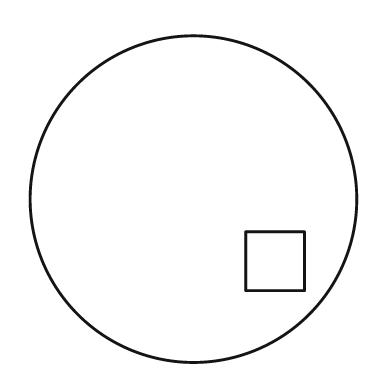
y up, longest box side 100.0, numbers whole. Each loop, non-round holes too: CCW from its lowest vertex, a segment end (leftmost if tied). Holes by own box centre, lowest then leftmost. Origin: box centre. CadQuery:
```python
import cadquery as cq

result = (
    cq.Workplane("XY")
    .moveTo(0.0, 0.0)
    .circle(50.0)
    .moveTo(16.0, -28.0)
    .lineTo(34.0, -28.0)
    .lineTo(34.0, -10.0)
    .lineTo(16.0, -10.0)
    .close()
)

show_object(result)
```